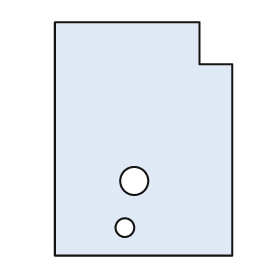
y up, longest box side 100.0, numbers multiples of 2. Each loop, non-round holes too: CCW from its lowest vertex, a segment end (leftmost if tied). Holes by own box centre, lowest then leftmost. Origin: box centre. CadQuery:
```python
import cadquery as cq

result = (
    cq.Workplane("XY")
    .moveTo(-38.0, -50.0)
    .lineTo(38.0, -50.0)
    .lineTo(38.0, 32.0)
    .lineTo(24.0, 32.0)
    .lineTo(24.0, 50.0)
    .lineTo(-38.0, 50.0)
    .close()
    .moveTo(-8.0, -38.0)
    .circle(4.0)
    .moveTo(-4.0, -18.0)
    .circle(6.0)
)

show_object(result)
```